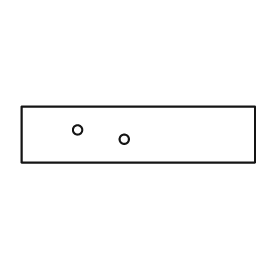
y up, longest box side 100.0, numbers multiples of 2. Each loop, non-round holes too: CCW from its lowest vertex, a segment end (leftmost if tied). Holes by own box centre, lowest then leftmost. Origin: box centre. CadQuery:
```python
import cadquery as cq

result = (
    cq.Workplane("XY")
    .moveTo(-50.0, -12.0)
    .lineTo(50.0, -12.0)
    .lineTo(50.0, 12.0)
    .lineTo(-50.0, 12.0)
    .close()
    .moveTo(-6.0, -2.0)
    .circle(2.0)
    .moveTo(-26.0, 2.0)
    .circle(2.0)
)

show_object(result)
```